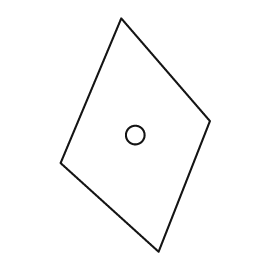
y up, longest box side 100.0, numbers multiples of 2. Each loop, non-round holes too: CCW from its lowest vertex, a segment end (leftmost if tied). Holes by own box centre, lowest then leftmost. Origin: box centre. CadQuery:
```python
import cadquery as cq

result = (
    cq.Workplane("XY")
    .moveTo(10.0, -50.0)
    .lineTo(32.0, 6.0)
    .lineTo(-6.0, 50.0)
    .lineTo(-32.0, -12.0)
    .close()
    .moveTo(0.0, 0.0)
    .circle(4.0)
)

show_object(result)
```